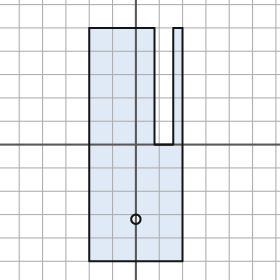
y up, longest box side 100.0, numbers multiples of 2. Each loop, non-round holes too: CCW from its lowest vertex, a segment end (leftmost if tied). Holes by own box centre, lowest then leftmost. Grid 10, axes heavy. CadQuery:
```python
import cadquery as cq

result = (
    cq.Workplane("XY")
    .moveTo(-20.0, -50.0)
    .lineTo(20.0, -50.0)
    .lineTo(20.0, 50.0)
    .lineTo(16.0, 50.0)
    .lineTo(16.0, 0.0)
    .lineTo(8.0, 0.0)
    .lineTo(8.0, 50.0)
    .lineTo(-20.0, 50.0)
    .close()
    .moveTo(0.0, -32.0)
    .circle(2.0)
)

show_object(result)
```